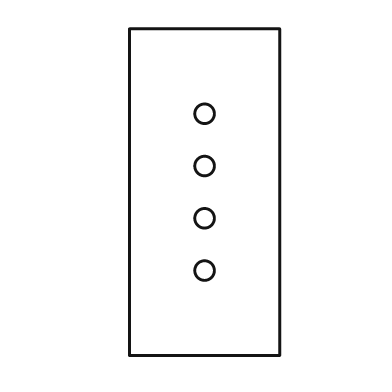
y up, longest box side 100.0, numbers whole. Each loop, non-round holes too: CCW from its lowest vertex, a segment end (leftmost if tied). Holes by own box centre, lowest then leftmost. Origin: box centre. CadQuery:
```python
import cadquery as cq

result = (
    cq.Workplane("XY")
    .moveTo(-23.0, -50.0)
    .lineTo(23.0, -50.0)
    .lineTo(23.0, 50.0)
    .lineTo(-23.0, 50.0)
    .close()
    .moveTo(0.0, -24.0)
    .circle(3.0)
    .moveTo(0.0, -8.0)
    .circle(3.0)
    .moveTo(0.0, 8.0)
    .circle(3.0)
    .moveTo(0.0, 24.0)
    .circle(3.0)
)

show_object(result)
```